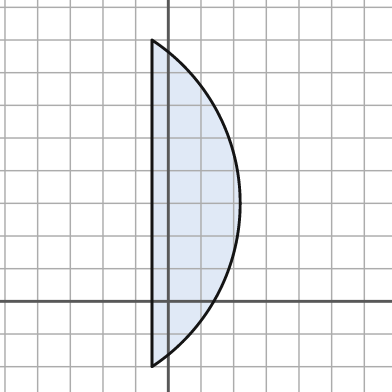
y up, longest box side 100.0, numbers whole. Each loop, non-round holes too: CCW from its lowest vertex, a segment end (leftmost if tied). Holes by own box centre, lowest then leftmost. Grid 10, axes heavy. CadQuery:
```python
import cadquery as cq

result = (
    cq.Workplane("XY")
    .moveTo(-5.0, -20.0)
    .threePointArc((22.0, 30.0), (-5.0, 80.0))
    .close()
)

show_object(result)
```